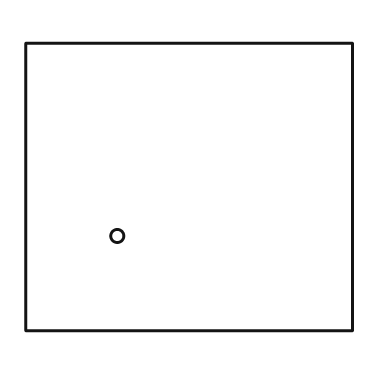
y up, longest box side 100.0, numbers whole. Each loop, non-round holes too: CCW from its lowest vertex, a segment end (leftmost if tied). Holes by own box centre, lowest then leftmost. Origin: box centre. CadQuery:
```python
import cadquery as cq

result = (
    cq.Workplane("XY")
    .moveTo(-50.0, -44.0)
    .lineTo(50.0, -44.0)
    .lineTo(50.0, 44.0)
    .lineTo(-50.0, 44.0)
    .close()
    .moveTo(-22.0, -15.0)
    .circle(2.0)
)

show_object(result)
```